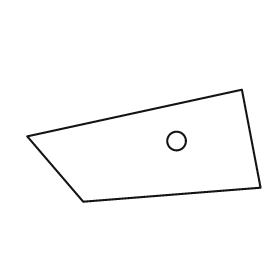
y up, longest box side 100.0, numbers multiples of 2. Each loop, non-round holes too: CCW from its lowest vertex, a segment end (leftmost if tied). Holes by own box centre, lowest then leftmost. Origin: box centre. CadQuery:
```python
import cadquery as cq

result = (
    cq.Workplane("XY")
    .moveTo(-26.0, -24.0)
    .lineTo(50.0, -18.0)
    .lineTo(42.0, 24.0)
    .lineTo(-50.0, 4.0)
    .close()
    .moveTo(14.0, 2.0)
    .circle(4.0)
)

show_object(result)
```